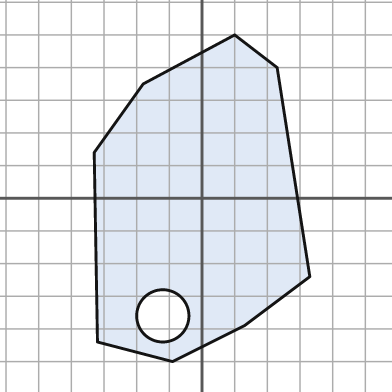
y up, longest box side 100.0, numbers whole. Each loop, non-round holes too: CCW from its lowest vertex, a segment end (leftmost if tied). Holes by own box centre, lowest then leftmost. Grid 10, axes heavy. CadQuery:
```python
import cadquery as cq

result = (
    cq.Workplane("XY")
    .moveTo(-9.0, -50.0)
    .lineTo(13.0, -39.0)
    .lineTo(33.0, -24.0)
    .lineTo(23.0, 40.0)
    .lineTo(10.0, 50.0)
    .lineTo(-18.0, 35.0)
    .lineTo(-33.0, 14.0)
    .lineTo(-32.0, -44.0)
    .close()
    .moveTo(-12.0, -36.0)
    .circle(8.0)
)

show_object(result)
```